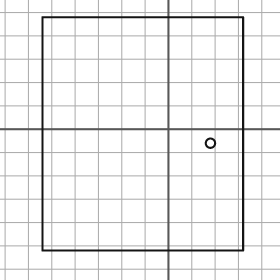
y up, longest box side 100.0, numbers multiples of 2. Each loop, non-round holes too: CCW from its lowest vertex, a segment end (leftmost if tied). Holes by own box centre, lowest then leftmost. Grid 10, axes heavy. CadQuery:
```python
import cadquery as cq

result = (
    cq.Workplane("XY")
    .moveTo(-54.0, -52.0)
    .lineTo(32.0, -52.0)
    .lineTo(32.0, 48.0)
    .lineTo(-54.0, 48.0)
    .close()
    .moveTo(18.0, -6.0)
    .circle(2.0)
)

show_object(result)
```